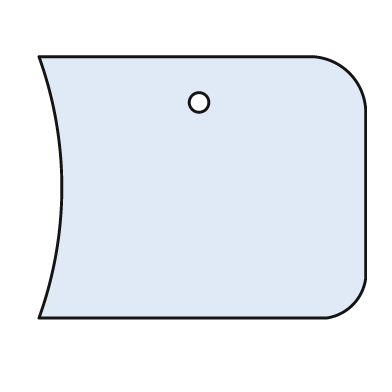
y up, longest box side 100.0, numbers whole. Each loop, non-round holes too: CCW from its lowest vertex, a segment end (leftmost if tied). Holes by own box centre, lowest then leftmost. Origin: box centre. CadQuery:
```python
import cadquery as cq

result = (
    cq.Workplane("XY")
    .moveTo(-50.0, -40.0)
    .lineTo(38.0, -40.0)
    .threePointArc((46.0, -36.0), (50.0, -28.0))
    .lineTo(50.0, 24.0)
    .threePointArc((45.0, 35.0), (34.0, 40.0))
    .lineTo(-50.0, 40.0)
    .threePointArc((-43.0, 0.0), (-50.0, -40.0))
    .close()
    .moveTo(-1.0, 26.0)
    .circle(3.0)
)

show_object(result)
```